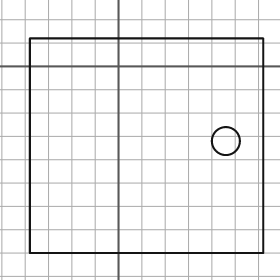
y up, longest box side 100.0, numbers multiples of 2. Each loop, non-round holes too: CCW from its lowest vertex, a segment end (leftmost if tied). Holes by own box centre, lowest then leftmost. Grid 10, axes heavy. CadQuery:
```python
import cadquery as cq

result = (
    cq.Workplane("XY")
    .moveTo(-38.0, -80.0)
    .lineTo(62.0, -80.0)
    .lineTo(62.0, 12.0)
    .lineTo(-38.0, 12.0)
    .close()
    .moveTo(46.0, -32.0)
    .circle(6.0)
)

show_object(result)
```